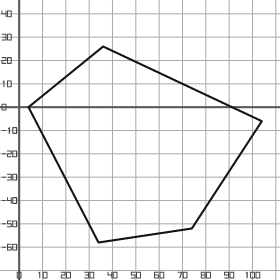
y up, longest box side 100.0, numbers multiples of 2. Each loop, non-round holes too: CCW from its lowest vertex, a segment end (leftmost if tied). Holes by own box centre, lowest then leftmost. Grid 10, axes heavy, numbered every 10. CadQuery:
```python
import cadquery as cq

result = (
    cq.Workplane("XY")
    .moveTo(34.0, -58.0)
    .lineTo(74.0, -52.0)
    .lineTo(104.0, -6.0)
    .lineTo(36.0, 26.0)
    .lineTo(4.0, 0.0)
    .close()
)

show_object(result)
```